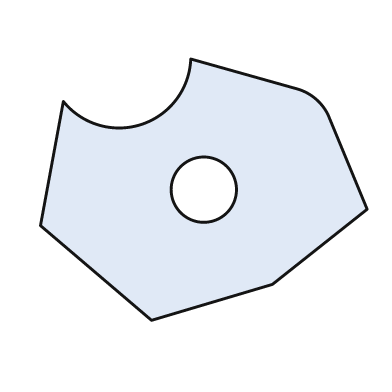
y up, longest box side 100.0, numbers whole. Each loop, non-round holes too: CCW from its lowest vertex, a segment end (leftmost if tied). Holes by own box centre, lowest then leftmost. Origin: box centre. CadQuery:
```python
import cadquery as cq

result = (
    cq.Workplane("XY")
    .moveTo(-16.0, -40.0)
    .lineTo(21.0, -29.0)
    .lineTo(50.0, -6.0)
    .lineTo(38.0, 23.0)
    .threePointArc((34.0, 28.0), (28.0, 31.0))
    .lineTo(-4.0, 40.0)
    .threePointArc((-19.0, 20.0), (-43.0, 27.0))
    .lineTo(-50.0, -11.0)
    .close()
    .moveTo(0.0, 0.0)
    .circle(10.0)
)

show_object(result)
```